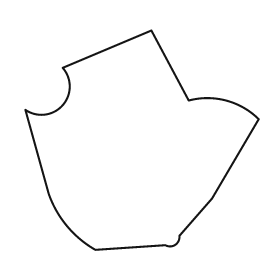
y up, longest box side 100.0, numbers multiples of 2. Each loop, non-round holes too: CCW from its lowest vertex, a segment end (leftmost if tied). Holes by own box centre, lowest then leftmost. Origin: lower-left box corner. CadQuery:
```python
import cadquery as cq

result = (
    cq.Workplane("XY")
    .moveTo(30.0, 0.0)
    .lineTo(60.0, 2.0)
    .threePointArc((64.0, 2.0), (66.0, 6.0))
    .lineTo(80.0, 22.0)
    .lineTo(100.0, 56.0)
    .threePointArc((86.0, 64.0), (70.0, 64.0))
    .lineTo(54.0, 94.0)
    .lineTo(16.0, 78.0)
    .threePointArc((16.0, 62.0), (0.0, 60.0))
    .lineTo(10.0, 24.0)
    .threePointArc((18.0, 10.0), (30.0, 0.0))
    .close()
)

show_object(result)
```